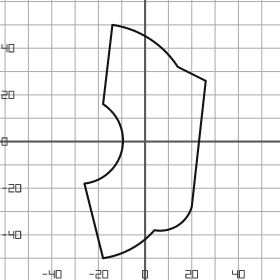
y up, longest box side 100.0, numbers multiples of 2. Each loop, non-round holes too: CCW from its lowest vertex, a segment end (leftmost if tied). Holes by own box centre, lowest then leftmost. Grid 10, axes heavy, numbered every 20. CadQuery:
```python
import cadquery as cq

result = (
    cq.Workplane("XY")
    .moveTo(-18.0, -50.0)
    .threePointArc((-6.0, -46.0), (4.0, -38.0))
    .threePointArc((14.0, -36.0), (20.0, -28.0))
    .lineTo(26.0, 26.0)
    .lineTo(14.0, 32.0)
    .threePointArc((2.0, 44.0), (-14.0, 50.0))
    .lineTo(-18.0, 16.0)
    .threePointArc((-10.0, -4.0), (-26.0, -18.0))
    .close()
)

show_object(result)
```